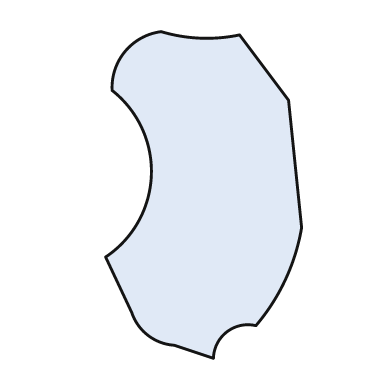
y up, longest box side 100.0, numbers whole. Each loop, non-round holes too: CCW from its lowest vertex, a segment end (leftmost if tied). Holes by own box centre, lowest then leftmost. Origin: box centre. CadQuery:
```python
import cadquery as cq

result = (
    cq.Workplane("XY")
    .moveTo(3.0, -50.0)
    .threePointArc((7.0, -42.0), (16.0, -40.0))
    .threePointArc((25.0, -26.0), (30.0, -10.0))
    .lineTo(26.0, 29.0)
    .lineTo(11.0, 49.0)
    .threePointArc((-1.0, 48.0), (-13.0, 50.0))
    .threePointArc((-24.0, 44.0), (-28.0, 32.0))
    .threePointArc((-16.0, 6.0), (-30.0, -19.0))
    .lineTo(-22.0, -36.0)
    .threePointArc((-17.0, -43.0), (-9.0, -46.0))
    .close()
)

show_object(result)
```